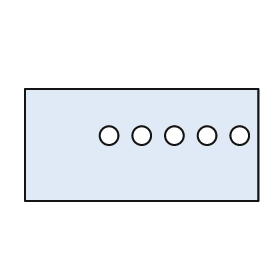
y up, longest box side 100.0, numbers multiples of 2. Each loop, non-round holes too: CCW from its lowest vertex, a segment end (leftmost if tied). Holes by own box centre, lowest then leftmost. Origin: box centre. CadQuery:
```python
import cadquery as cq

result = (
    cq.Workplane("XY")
    .moveTo(-50.0, -24.0)
    .lineTo(50.0, -24.0)
    .lineTo(50.0, 24.0)
    .lineTo(-50.0, 24.0)
    .close()
    .moveTo(-14.0, 4.0)
    .circle(4.0)
    .moveTo(0.0, 4.0)
    .circle(4.0)
    .moveTo(14.0, 4.0)
    .circle(4.0)
    .moveTo(28.0, 4.0)
    .circle(4.0)
    .moveTo(42.0, 4.0)
    .circle(4.0)
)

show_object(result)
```